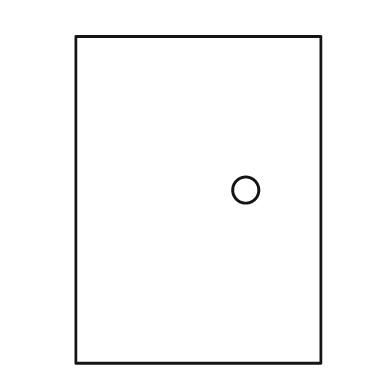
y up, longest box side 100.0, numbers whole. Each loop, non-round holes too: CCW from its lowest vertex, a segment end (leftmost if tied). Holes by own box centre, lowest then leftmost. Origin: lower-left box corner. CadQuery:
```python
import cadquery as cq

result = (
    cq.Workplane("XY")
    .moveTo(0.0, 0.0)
    .lineTo(75.0, 0.0)
    .lineTo(75.0, 100.0)
    .lineTo(0.0, 100.0)
    .close()
    .moveTo(52.0, 53.0)
    .circle(4.0)
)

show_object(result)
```